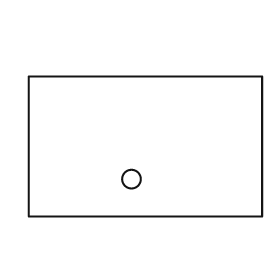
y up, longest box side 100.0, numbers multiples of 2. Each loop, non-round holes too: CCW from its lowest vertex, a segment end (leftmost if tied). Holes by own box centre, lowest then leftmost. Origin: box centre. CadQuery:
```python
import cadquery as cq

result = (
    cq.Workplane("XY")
    .moveTo(-50.0, -30.0)
    .lineTo(50.0, -30.0)
    .lineTo(50.0, 30.0)
    .lineTo(-50.0, 30.0)
    .close()
    .moveTo(-6.0, -14.0)
    .circle(4.0)
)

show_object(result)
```